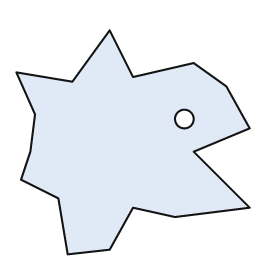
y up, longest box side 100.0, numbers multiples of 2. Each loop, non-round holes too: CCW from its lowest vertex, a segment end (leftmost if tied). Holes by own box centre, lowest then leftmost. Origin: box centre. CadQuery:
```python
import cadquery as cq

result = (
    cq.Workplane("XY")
    .moveTo(-28.0, -48.0)
    .lineTo(-10.0, -46.0)
    .lineTo(0.0, -28.0)
    .lineTo(18.0, -32.0)
    .lineTo(50.0, -28.0)
    .lineTo(26.0, -4.0)
    .lineTo(50.0, 6.0)
    .lineTo(40.0, 24.0)
    .lineTo(26.0, 34.0)
    .lineTo(0.0, 28.0)
    .lineTo(-10.0, 48.0)
    .lineTo(-26.0, 26.0)
    .lineTo(-50.0, 30.0)
    .lineTo(-42.0, 12.0)
    .lineTo(-44.0, -4.0)
    .lineTo(-48.0, -16.0)
    .lineTo(-32.0, -24.0)
    .close()
    .moveTo(22.0, 10.0)
    .circle(4.0)
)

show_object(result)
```